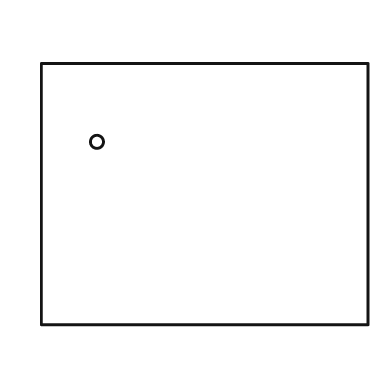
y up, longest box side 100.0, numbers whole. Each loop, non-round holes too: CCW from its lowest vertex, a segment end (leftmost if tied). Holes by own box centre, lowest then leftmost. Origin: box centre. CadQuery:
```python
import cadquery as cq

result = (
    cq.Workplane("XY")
    .moveTo(-50.0, -40.0)
    .lineTo(50.0, -40.0)
    .lineTo(50.0, 40.0)
    .lineTo(-50.0, 40.0)
    .close()
    .moveTo(-33.0, 16.0)
    .circle(2.0)
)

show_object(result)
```